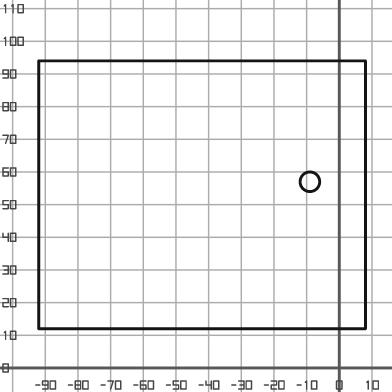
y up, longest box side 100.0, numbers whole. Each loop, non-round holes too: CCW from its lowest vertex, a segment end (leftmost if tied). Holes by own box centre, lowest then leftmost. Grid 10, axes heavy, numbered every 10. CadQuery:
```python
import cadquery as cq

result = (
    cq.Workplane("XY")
    .moveTo(-92.0, 12.0)
    .lineTo(8.0, 12.0)
    .lineTo(8.0, 94.0)
    .lineTo(-92.0, 94.0)
    .close()
    .moveTo(-9.0, 57.0)
    .circle(3.0)
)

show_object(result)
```